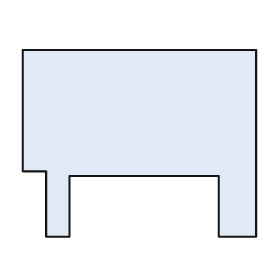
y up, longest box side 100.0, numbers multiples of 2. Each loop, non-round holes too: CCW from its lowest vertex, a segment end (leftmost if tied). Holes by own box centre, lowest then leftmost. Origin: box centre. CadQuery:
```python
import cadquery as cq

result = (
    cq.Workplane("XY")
    .moveTo(-40.0, -40.0)
    .lineTo(-30.0, -40.0)
    .lineTo(-30.0, -14.0)
    .lineTo(34.0, -14.0)
    .lineTo(34.0, -40.0)
    .lineTo(50.0, -40.0)
    .lineTo(50.0, 40.0)
    .lineTo(-50.0, 40.0)
    .lineTo(-50.0, -12.0)
    .lineTo(-40.0, -12.0)
    .close()
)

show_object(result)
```